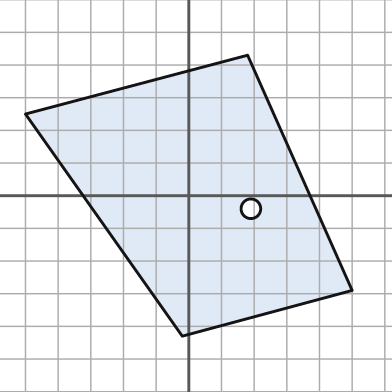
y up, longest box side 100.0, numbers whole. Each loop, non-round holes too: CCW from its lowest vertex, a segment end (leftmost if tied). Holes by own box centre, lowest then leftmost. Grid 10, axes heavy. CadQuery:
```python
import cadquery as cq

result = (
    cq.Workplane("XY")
    .moveTo(-2.0, -43.0)
    .lineTo(50.0, -29.0)
    .lineTo(18.0, 43.0)
    .lineTo(-50.0, 25.0)
    .close()
    .moveTo(19.0, -4.0)
    .circle(3.0)
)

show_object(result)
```